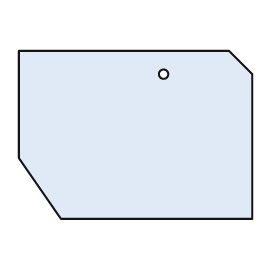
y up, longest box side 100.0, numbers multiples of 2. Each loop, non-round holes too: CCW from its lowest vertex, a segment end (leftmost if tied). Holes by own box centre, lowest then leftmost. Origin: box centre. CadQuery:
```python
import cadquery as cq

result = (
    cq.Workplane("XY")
    .moveTo(-32.0, -36.0)
    .lineTo(50.0, -36.0)
    .lineTo(50.0, 26.0)
    .lineTo(40.0, 36.0)
    .lineTo(-50.0, 36.0)
    .lineTo(-50.0, -10.0)
    .close()
    .moveTo(12.0, 26.0)
    .circle(2.0)
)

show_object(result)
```